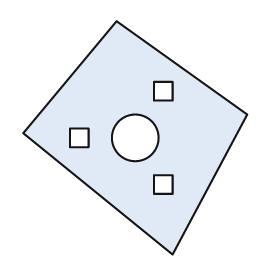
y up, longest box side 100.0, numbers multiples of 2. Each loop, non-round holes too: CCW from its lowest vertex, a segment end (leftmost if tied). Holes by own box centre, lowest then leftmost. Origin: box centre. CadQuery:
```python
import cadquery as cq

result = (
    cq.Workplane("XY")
    .moveTo(16.0, -50.0)
    .lineTo(48.0, 10.0)
    .lineTo(-8.0, 50.0)
    .lineTo(-48.0, 2.0)
    .close()
    .moveTo(8.0, -24.0)
    .lineTo(16.0, -24.0)
    .lineTo(16.0, -16.0)
    .lineTo(8.0, -16.0)
    .close()
    .moveTo(-28.0, -4.0)
    .lineTo(-20.0, -4.0)
    .lineTo(-20.0, 4.0)
    .lineTo(-28.0, 4.0)
    .close()
    .moveTo(0.0, 0.0)
    .circle(10.0)
    .moveTo(8.0, 16.0)
    .lineTo(16.0, 16.0)
    .lineTo(16.0, 24.0)
    .lineTo(8.0, 24.0)
    .close()
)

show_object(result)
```